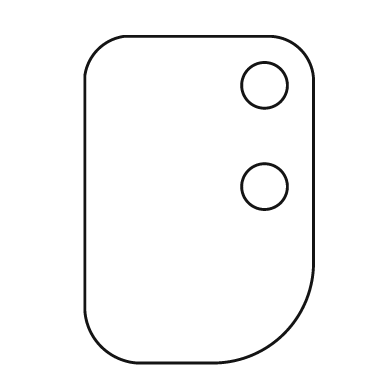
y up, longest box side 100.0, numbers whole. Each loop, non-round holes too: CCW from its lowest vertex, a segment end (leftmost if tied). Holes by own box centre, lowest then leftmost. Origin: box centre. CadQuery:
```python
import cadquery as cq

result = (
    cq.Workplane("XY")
    .moveTo(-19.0, -50.0)
    .lineTo(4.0, -50.0)
    .threePointArc((26.0, -41.0), (35.0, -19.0))
    .lineTo(35.0, 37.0)
    .threePointArc((31.0, 46.0), (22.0, 50.0))
    .lineTo(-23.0, 50.0)
    .threePointArc((-31.0, 46.0), (-35.0, 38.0))
    .lineTo(-35.0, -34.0)
    .threePointArc((-30.0, -45.0), (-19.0, -50.0))
    .close()
    .moveTo(20.0, 4.0)
    .circle(7.0)
    .moveTo(20.0, 35.0)
    .circle(7.0)
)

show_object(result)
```